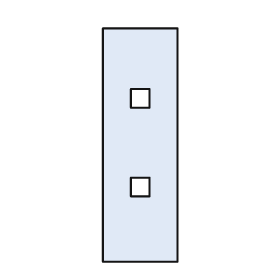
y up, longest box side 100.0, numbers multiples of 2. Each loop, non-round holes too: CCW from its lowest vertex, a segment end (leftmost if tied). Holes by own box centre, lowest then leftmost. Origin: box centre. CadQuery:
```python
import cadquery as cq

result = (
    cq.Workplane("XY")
    .moveTo(-16.0, -50.0)
    .lineTo(16.0, -50.0)
    .lineTo(16.0, 50.0)
    .lineTo(-16.0, 50.0)
    .close()
    .moveTo(-4.0, -22.0)
    .lineTo(4.0, -22.0)
    .lineTo(4.0, -14.0)
    .lineTo(-4.0, -14.0)
    .close()
    .moveTo(-4.0, 16.0)
    .lineTo(4.0, 16.0)
    .lineTo(4.0, 24.0)
    .lineTo(-4.0, 24.0)
    .close()
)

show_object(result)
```